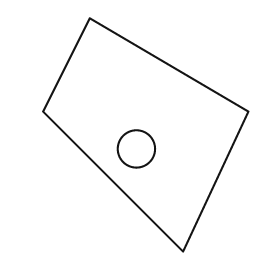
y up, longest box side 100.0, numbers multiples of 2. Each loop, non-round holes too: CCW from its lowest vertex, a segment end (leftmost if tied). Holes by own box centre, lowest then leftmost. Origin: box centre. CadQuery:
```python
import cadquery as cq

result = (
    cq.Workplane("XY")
    .moveTo(16.0, -50.0)
    .lineTo(44.0, 10.0)
    .lineTo(-24.0, 50.0)
    .lineTo(-44.0, 10.0)
    .close()
    .moveTo(-4.0, -6.0)
    .circle(8.0)
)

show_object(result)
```